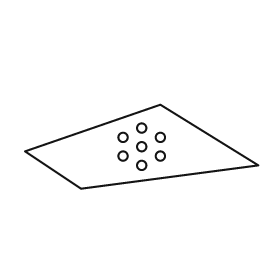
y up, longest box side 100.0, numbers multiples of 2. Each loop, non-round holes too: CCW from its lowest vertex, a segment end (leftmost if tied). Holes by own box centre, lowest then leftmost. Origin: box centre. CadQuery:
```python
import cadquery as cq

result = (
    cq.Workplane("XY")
    .moveTo(-26.0, -18.0)
    .lineTo(50.0, -8.0)
    .lineTo(8.0, 18.0)
    .lineTo(-50.0, -2.0)
    .close()
    .moveTo(0.0, -8.0)
    .circle(2.0)
    .moveTo(-8.0, -4.0)
    .circle(2.0)
    .moveTo(8.0, -4.0)
    .circle(2.0)
    .moveTo(0.0, 0.0)
    .circle(2.0)
    .moveTo(-8.0, 4.0)
    .circle(2.0)
    .moveTo(8.0, 4.0)
    .circle(2.0)
    .moveTo(0.0, 8.0)
    .circle(2.0)
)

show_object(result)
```